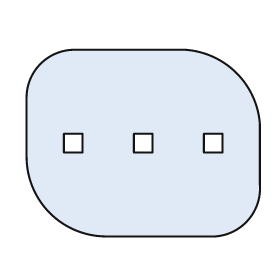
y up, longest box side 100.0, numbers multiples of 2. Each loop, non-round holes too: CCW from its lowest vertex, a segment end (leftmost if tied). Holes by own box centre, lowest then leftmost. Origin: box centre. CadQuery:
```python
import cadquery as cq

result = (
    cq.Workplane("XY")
    .moveTo(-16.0, -40.0)
    .lineTo(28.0, -40.0)
    .threePointArc((44.0, -34.0), (50.0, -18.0))
    .lineTo(50.0, 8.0)
    .threePointArc((40.0, 30.0), (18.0, 40.0))
    .lineTo(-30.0, 40.0)
    .threePointArc((-44.0, 34.0), (-50.0, 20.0))
    .lineTo(-50.0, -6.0)
    .threePointArc((-40.0, -30.0), (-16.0, -40.0))
    .close()
    .moveTo(-34.0, -4.0)
    .lineTo(-26.0, -4.0)
    .lineTo(-26.0, 4.0)
    .lineTo(-34.0, 4.0)
    .close()
    .moveTo(-4.0, -4.0)
    .lineTo(4.0, -4.0)
    .lineTo(4.0, 4.0)
    .lineTo(-4.0, 4.0)
    .close()
    .moveTo(26.0, -4.0)
    .lineTo(34.0, -4.0)
    .lineTo(34.0, 4.0)
    .lineTo(26.0, 4.0)
    .close()
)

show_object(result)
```